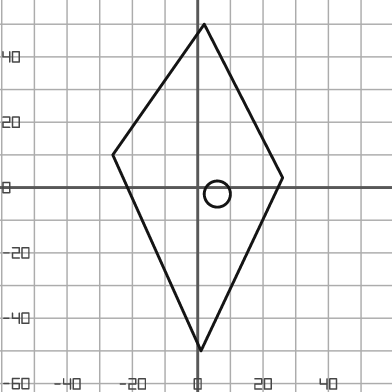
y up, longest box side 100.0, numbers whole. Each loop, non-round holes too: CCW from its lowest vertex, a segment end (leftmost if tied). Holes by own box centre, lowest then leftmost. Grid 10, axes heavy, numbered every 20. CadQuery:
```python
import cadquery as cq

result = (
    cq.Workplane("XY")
    .moveTo(1.0, -50.0)
    .lineTo(26.0, 3.0)
    .lineTo(2.0, 50.0)
    .lineTo(-26.0, 10.0)
    .close()
    .moveTo(6.0, -2.0)
    .circle(4.0)
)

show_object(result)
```